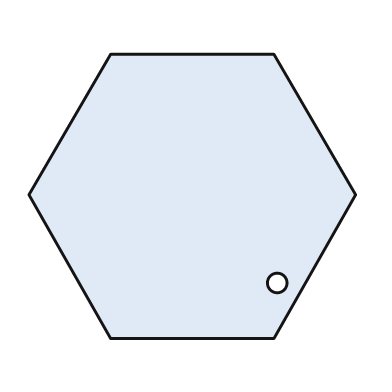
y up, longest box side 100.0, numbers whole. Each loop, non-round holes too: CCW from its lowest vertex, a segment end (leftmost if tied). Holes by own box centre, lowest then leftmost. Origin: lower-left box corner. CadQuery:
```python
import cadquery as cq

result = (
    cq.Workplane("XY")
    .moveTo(25.0, 0.0)
    .lineTo(75.0, 0.0)
    .lineTo(100.0, 44.0)
    .lineTo(75.0, 87.0)
    .lineTo(25.0, 87.0)
    .lineTo(0.0, 44.0)
    .close()
    .moveTo(76.0, 17.0)
    .circle(3.0)
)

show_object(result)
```